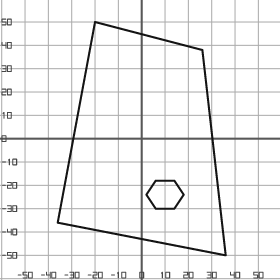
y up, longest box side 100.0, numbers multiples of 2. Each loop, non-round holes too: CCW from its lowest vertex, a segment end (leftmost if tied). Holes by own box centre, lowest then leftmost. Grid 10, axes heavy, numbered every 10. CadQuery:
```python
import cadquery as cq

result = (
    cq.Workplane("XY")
    .moveTo(36.0, -50.0)
    .lineTo(26.0, 38.0)
    .lineTo(-20.0, 50.0)
    .lineTo(-36.0, -36.0)
    .close()
    .moveTo(6.0, -30.0)
    .lineTo(14.0, -30.0)
    .lineTo(18.0, -24.0)
    .lineTo(14.0, -18.0)
    .lineTo(6.0, -18.0)
    .lineTo(2.0, -24.0)
    .close()
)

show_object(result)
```